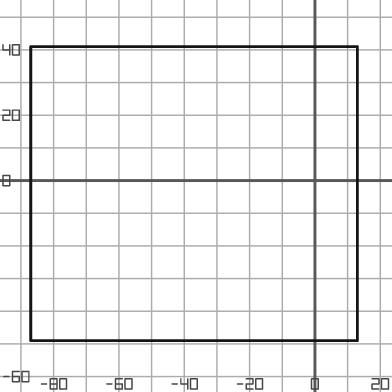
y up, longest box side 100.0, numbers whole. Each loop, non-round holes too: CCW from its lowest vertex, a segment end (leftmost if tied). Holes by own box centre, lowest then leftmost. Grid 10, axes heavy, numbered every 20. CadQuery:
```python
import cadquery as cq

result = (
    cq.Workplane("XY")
    .moveTo(-87.0, -49.0)
    .lineTo(13.0, -49.0)
    .lineTo(13.0, 41.0)
    .lineTo(-87.0, 41.0)
    .close()
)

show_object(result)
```